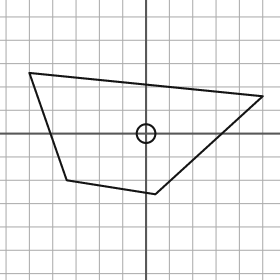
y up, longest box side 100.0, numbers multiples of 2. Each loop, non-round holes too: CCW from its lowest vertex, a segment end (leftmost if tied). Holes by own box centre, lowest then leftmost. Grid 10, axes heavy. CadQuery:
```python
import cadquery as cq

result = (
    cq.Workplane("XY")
    .moveTo(4.0, -26.0)
    .lineTo(50.0, 16.0)
    .lineTo(-50.0, 26.0)
    .lineTo(-34.0, -20.0)
    .close()
    .moveTo(0.0, 0.0)
    .circle(4.0)
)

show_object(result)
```